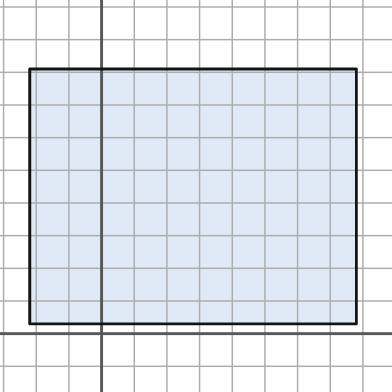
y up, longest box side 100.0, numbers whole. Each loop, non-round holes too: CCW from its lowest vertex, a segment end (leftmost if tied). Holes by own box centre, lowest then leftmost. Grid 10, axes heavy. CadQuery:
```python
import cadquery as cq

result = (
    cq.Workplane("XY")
    .moveTo(-22.0, 3.0)
    .lineTo(78.0, 3.0)
    .lineTo(78.0, 81.0)
    .lineTo(-22.0, 81.0)
    .close()
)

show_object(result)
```